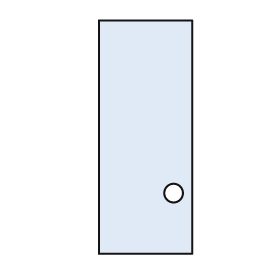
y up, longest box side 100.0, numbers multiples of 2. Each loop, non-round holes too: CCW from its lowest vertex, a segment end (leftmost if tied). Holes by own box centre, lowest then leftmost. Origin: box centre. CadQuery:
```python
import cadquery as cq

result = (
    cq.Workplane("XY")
    .moveTo(-20.0, -50.0)
    .lineTo(20.0, -50.0)
    .lineTo(20.0, 50.0)
    .lineTo(-20.0, 50.0)
    .close()
    .moveTo(12.0, -24.0)
    .circle(4.0)
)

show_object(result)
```